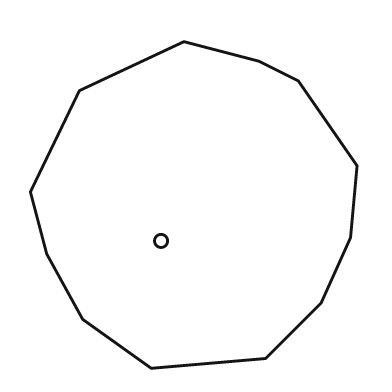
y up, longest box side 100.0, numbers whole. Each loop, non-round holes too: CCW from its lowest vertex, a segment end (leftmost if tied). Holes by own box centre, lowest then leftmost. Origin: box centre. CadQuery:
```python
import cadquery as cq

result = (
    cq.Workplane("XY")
    .moveTo(-13.0, -50.0)
    .lineTo(22.0, -47.0)
    .lineTo(39.0, -30.0)
    .lineTo(48.0, -10.0)
    .lineTo(50.0, 12.0)
    .lineTo(32.0, 38.0)
    .lineTo(20.0, 44.0)
    .lineTo(-3.0, 50.0)
    .lineTo(-35.0, 35.0)
    .lineTo(-50.0, 4.0)
    .lineTo(-45.0, -15.0)
    .lineTo(-34.0, -35.0)
    .close()
    .moveTo(-10.0, -11.0)
    .circle(2.0)
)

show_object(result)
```